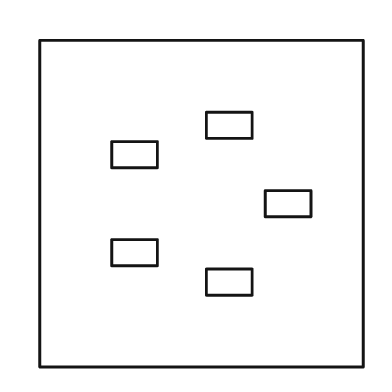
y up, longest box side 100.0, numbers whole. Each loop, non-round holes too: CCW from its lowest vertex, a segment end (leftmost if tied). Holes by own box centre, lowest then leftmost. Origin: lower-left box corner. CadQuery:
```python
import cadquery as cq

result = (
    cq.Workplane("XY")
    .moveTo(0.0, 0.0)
    .lineTo(99.0, 0.0)
    .lineTo(99.0, 100.0)
    .lineTo(0.0, 100.0)
    .close()
    .moveTo(51.0, 22.0)
    .lineTo(65.0, 22.0)
    .lineTo(65.0, 30.0)
    .lineTo(51.0, 30.0)
    .close()
    .moveTo(22.0, 31.0)
    .lineTo(36.0, 31.0)
    .lineTo(36.0, 39.0)
    .lineTo(22.0, 39.0)
    .close()
    .moveTo(69.0, 46.0)
    .lineTo(83.0, 46.0)
    .lineTo(83.0, 54.0)
    .lineTo(69.0, 54.0)
    .close()
    .moveTo(22.0, 61.0)
    .lineTo(36.0, 61.0)
    .lineTo(36.0, 69.0)
    .lineTo(22.0, 69.0)
    .close()
    .moveTo(51.0, 70.0)
    .lineTo(65.0, 70.0)
    .lineTo(65.0, 78.0)
    .lineTo(51.0, 78.0)
    .close()
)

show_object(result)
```